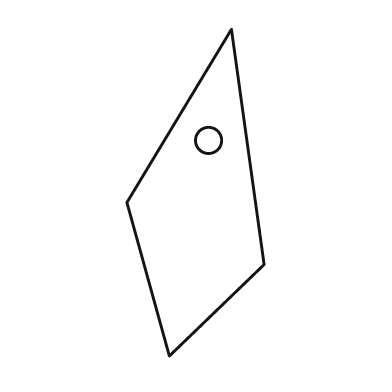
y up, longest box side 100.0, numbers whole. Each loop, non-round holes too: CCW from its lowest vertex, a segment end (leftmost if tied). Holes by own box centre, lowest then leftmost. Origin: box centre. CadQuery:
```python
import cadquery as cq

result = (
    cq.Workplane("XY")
    .moveTo(-8.0, -50.0)
    .lineTo(21.0, -22.0)
    .lineTo(11.0, 50.0)
    .lineTo(-21.0, -3.0)
    .close()
    .moveTo(4.0, 16.0)
    .circle(4.0)
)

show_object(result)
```